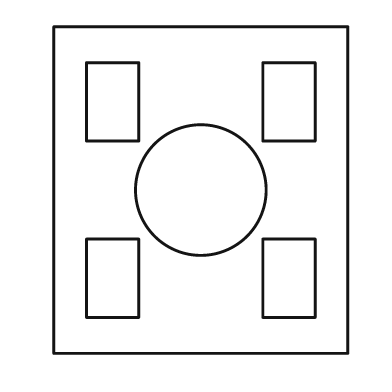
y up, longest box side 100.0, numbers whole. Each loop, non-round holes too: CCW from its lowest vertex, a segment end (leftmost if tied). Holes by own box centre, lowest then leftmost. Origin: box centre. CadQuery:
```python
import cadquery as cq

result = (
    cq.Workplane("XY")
    .moveTo(-45.0, -50.0)
    .lineTo(45.0, -50.0)
    .lineTo(45.0, 50.0)
    .lineTo(-45.0, 50.0)
    .close()
    .moveTo(-35.0, -39.0)
    .lineTo(-19.0, -39.0)
    .lineTo(-19.0, -15.0)
    .lineTo(-35.0, -15.0)
    .close()
    .moveTo(19.0, -39.0)
    .lineTo(35.0, -39.0)
    .lineTo(35.0, -15.0)
    .lineTo(19.0, -15.0)
    .close()
    .moveTo(0.0, 0.0)
    .circle(20.0)
    .moveTo(-35.0, 15.0)
    .lineTo(-19.0, 15.0)
    .lineTo(-19.0, 39.0)
    .lineTo(-35.0, 39.0)
    .close()
    .moveTo(19.0, 15.0)
    .lineTo(35.0, 15.0)
    .lineTo(35.0, 39.0)
    .lineTo(19.0, 39.0)
    .close()
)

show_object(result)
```